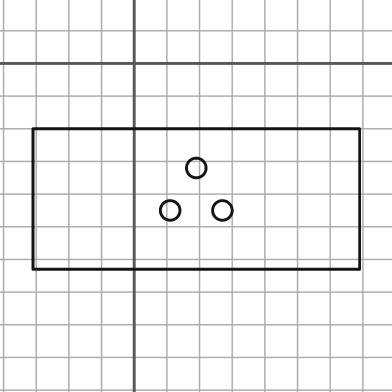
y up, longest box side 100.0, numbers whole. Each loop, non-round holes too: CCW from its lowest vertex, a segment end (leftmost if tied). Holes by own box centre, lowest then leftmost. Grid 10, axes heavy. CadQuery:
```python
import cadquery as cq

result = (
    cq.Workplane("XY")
    .moveTo(-31.0, -63.0)
    .lineTo(69.0, -63.0)
    .lineTo(69.0, -20.0)
    .lineTo(-31.0, -20.0)
    .close()
    .moveTo(11.0, -45.0)
    .circle(3.0)
    .moveTo(27.0, -45.0)
    .circle(3.0)
    .moveTo(19.0, -32.0)
    .circle(3.0)
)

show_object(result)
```